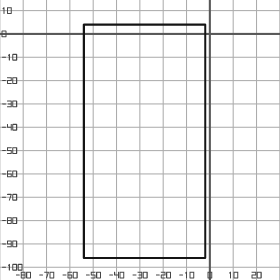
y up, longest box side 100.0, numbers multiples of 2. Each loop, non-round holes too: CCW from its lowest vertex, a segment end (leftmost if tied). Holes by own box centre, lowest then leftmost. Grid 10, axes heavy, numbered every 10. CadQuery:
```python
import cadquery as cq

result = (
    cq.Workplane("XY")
    .moveTo(-54.0, -96.0)
    .lineTo(-2.0, -96.0)
    .lineTo(-2.0, 4.0)
    .lineTo(-54.0, 4.0)
    .close()
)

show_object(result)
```